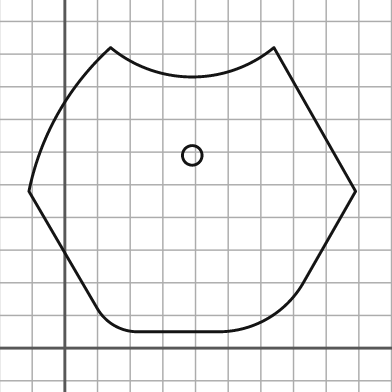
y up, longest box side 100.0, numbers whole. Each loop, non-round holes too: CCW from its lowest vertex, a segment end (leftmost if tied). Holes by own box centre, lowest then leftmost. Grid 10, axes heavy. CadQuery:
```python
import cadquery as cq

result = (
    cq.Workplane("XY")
    .moveTo(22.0, 5.0)
    .lineTo(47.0, 5.0)
    .threePointArc((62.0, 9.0), (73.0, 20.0))
    .lineTo(89.0, 48.0)
    .lineTo(64.0, 92.0)
    .threePointArc((39.0, 83.0), (14.0, 92.0))
    .threePointArc((-2.0, 72.0), (-11.0, 48.0))
    .lineTo(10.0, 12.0)
    .threePointArc((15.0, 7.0), (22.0, 5.0))
    .close()
    .moveTo(39.0, 59.0)
    .circle(3.0)
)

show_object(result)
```